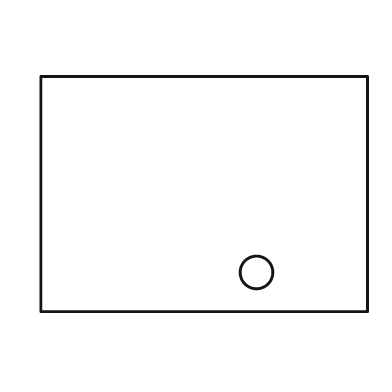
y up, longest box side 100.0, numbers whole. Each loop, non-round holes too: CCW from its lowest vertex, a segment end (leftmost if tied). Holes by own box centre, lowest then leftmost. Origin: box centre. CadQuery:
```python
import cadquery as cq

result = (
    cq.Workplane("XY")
    .moveTo(-50.0, -36.0)
    .lineTo(50.0, -36.0)
    .lineTo(50.0, 36.0)
    .lineTo(-50.0, 36.0)
    .close()
    .moveTo(16.0, -24.0)
    .circle(5.0)
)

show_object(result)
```